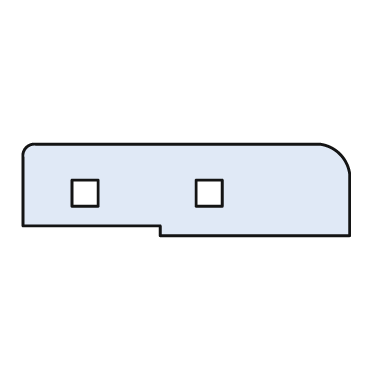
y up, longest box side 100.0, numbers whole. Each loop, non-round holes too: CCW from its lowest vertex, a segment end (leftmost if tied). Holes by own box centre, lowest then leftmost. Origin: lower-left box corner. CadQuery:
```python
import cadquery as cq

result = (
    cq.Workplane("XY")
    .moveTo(42.0, 0.0)
    .lineTo(100.0, 0.0)
    .lineTo(100.0, 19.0)
    .threePointArc((97.0, 25.0), (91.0, 28.0))
    .lineTo(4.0, 28.0)
    .threePointArc((1.0, 27.0), (0.0, 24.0))
    .lineTo(0.0, 3.0)
    .lineTo(42.0, 3.0)
    .close()
    .moveTo(15.0, 9.0)
    .lineTo(23.0, 9.0)
    .lineTo(23.0, 17.0)
    .lineTo(15.0, 17.0)
    .close()
    .moveTo(53.0, 9.0)
    .lineTo(61.0, 9.0)
    .lineTo(61.0, 17.0)
    .lineTo(53.0, 17.0)
    .close()
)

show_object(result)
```